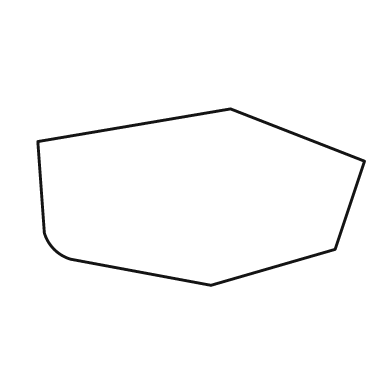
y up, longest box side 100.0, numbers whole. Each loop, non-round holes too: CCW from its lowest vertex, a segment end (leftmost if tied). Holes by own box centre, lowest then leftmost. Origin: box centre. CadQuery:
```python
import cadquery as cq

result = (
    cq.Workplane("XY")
    .moveTo(3.0, -27.0)
    .lineTo(41.0, -16.0)
    .lineTo(50.0, 11.0)
    .lineTo(9.0, 27.0)
    .lineTo(-50.0, 17.0)
    .lineTo(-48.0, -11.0)
    .threePointArc((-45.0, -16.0), (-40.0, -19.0))
    .close()
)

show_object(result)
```